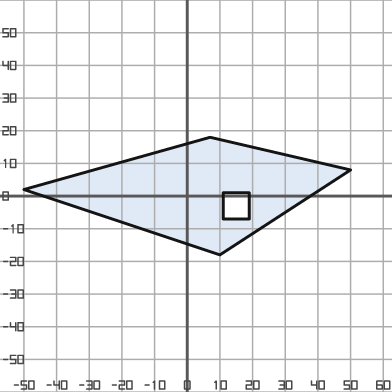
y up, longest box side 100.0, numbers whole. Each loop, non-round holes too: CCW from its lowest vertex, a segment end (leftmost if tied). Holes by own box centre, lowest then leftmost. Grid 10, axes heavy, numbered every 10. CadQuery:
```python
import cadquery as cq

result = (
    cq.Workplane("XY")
    .moveTo(10.0, -18.0)
    .lineTo(50.0, 8.0)
    .lineTo(7.0, 18.0)
    .lineTo(-50.0, 2.0)
    .close()
    .moveTo(11.0, -7.0)
    .lineTo(19.0, -7.0)
    .lineTo(19.0, 1.0)
    .lineTo(11.0, 1.0)
    .close()
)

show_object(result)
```